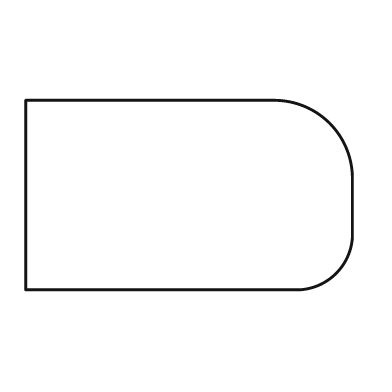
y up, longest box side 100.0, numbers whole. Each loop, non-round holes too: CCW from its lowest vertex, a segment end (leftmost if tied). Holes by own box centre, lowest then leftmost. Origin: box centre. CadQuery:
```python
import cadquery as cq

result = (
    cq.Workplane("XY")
    .moveTo(-50.0, -29.0)
    .lineTo(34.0, -29.0)
    .threePointArc((45.0, -24.0), (50.0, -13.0))
    .lineTo(50.0, 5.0)
    .threePointArc((43.0, 22.0), (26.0, 29.0))
    .lineTo(-50.0, 29.0)
    .close()
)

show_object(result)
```